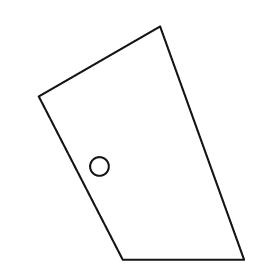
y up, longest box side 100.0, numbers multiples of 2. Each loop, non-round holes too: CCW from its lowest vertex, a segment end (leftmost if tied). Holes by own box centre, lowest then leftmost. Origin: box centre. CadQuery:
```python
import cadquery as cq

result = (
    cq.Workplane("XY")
    .moveTo(-8.0, -50.0)
    .lineTo(44.0, -50.0)
    .lineTo(8.0, 50.0)
    .lineTo(-44.0, 20.0)
    .close()
    .moveTo(-18.0, -10.0)
    .circle(4.0)
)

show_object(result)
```